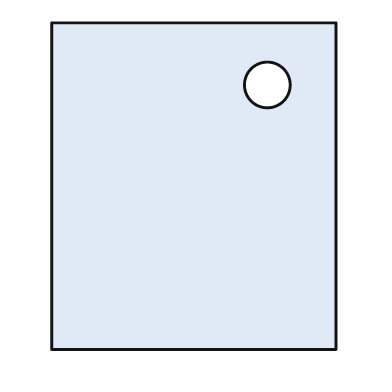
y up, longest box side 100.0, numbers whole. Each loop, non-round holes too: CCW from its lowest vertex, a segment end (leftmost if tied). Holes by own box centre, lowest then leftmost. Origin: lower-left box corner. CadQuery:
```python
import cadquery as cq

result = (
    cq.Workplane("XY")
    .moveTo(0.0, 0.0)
    .lineTo(87.0, 0.0)
    .lineTo(87.0, 100.0)
    .lineTo(0.0, 100.0)
    .close()
    .moveTo(66.0, 81.0)
    .circle(7.0)
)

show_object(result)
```